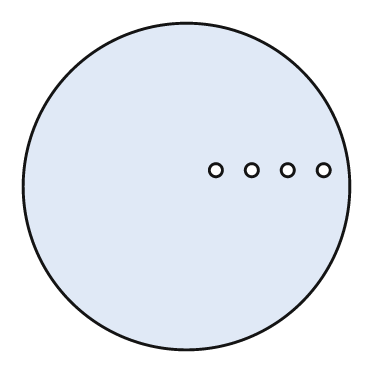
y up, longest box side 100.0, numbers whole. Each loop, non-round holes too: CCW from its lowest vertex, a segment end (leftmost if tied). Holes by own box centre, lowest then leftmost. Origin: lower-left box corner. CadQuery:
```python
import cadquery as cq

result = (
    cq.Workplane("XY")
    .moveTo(50.0, 50.0)
    .circle(50.0)
    .moveTo(59.0, 55.0)
    .circle(2.0)
    .moveTo(70.0, 55.0)
    .circle(2.0)
    .moveTo(81.0, 55.0)
    .circle(2.0)
    .moveTo(92.0, 55.0)
    .circle(2.0)
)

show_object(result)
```